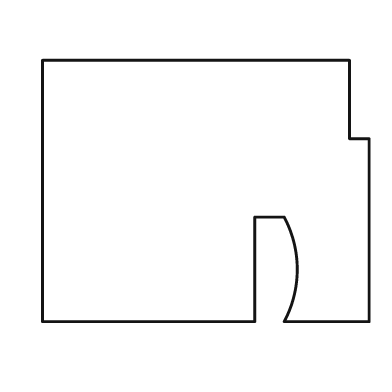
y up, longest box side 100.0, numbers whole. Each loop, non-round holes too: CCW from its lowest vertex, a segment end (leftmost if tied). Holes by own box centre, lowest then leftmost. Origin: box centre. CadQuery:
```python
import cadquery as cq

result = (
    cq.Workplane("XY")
    .moveTo(-50.0, -40.0)
    .lineTo(15.0, -40.0)
    .lineTo(15.0, -8.0)
    .lineTo(24.0, -8.0)
    .threePointArc((28.0, -24.0), (24.0, -40.0))
    .lineTo(50.0, -40.0)
    .lineTo(50.0, 16.0)
    .lineTo(44.0, 16.0)
    .lineTo(44.0, 40.0)
    .lineTo(-50.0, 40.0)
    .close()
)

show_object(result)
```